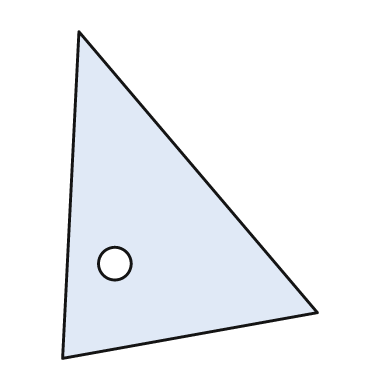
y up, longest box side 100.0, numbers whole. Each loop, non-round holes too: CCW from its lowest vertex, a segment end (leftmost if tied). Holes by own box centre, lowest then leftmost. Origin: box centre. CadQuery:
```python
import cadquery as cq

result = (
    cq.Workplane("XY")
    .moveTo(-39.0, -50.0)
    .lineTo(39.0, -36.0)
    .lineTo(-34.0, 50.0)
    .close()
    .moveTo(-23.0, -21.0)
    .circle(5.0)
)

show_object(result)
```